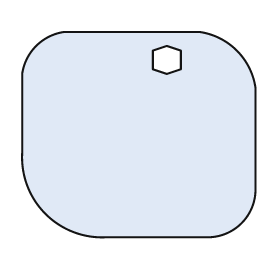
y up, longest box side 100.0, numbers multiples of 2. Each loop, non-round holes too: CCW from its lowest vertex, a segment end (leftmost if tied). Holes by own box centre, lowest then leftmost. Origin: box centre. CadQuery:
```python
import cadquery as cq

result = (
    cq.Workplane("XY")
    .moveTo(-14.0, -44.0)
    .lineTo(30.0, -44.0)
    .threePointArc((44.0, -38.0), (50.0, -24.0))
    .lineTo(50.0, 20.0)
    .threePointArc((42.0, 36.0), (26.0, 44.0))
    .lineTo(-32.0, 44.0)
    .threePointArc((-44.0, 38.0), (-50.0, 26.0))
    .lineTo(-50.0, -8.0)
    .threePointArc((-40.0, -34.0), (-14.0, -44.0))
    .close()
    .moveTo(12.0, 26.0)
    .lineTo(18.0, 28.0)
    .lineTo(18.0, 36.0)
    .lineTo(12.0, 38.0)
    .lineTo(6.0, 36.0)
    .lineTo(6.0, 28.0)
    .close()
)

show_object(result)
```